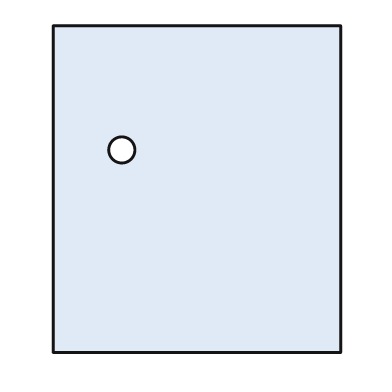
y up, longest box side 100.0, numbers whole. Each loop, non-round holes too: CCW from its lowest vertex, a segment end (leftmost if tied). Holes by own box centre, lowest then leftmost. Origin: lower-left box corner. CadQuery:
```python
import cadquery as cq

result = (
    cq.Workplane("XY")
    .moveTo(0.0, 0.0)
    .lineTo(88.0, 0.0)
    .lineTo(88.0, 100.0)
    .lineTo(0.0, 100.0)
    .close()
    .moveTo(21.0, 62.0)
    .circle(4.0)
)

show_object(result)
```